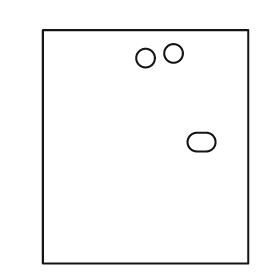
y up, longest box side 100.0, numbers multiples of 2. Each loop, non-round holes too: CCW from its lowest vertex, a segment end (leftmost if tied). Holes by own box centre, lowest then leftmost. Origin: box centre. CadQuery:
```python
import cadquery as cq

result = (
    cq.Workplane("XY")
    .moveTo(-44.0, -50.0)
    .lineTo(44.0, -50.0)
    .lineTo(44.0, 50.0)
    .lineTo(-44.0, 50.0)
    .close()
    .moveTo(22.0, -2.0)
    .lineTo(26.0, -2.0)
    .threePointArc((30.0, 2.0), (26.0, 6.0))
    .lineTo(22.0, 6.0)
    .threePointArc((18.0, 2.0), (22.0, -2.0))
    .close()
    .moveTo(0.0, 38.0)
    .circle(4.0)
    .moveTo(12.0, 40.0)
    .circle(4.0)
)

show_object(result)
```